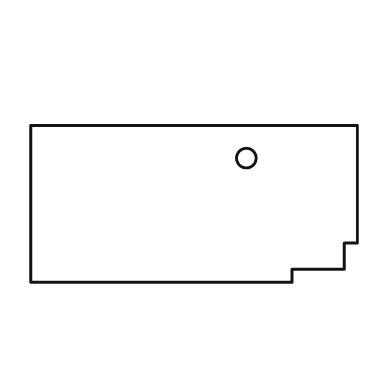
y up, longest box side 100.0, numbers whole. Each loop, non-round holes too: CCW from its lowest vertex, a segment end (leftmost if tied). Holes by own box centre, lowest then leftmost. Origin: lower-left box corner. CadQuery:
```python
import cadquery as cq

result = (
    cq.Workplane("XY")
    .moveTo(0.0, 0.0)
    .lineTo(80.0, 0.0)
    .lineTo(80.0, 4.0)
    .lineTo(96.0, 4.0)
    .lineTo(96.0, 12.0)
    .lineTo(100.0, 12.0)
    .lineTo(100.0, 48.0)
    .lineTo(0.0, 48.0)
    .close()
    .moveTo(66.0, 38.0)
    .circle(3.0)
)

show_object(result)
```